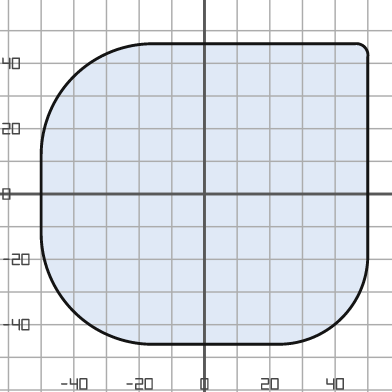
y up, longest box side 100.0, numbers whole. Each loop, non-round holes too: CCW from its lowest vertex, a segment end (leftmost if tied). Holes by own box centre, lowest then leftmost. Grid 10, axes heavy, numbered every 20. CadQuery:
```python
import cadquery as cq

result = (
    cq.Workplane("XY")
    .moveTo(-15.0, -46.0)
    .lineTo(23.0, -46.0)
    .threePointArc((42.0, -38.0), (50.0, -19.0))
    .lineTo(50.0, 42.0)
    .threePointArc((49.0, 45.0), (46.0, 46.0))
    .lineTo(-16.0, 46.0)
    .threePointArc((-40.0, 36.0), (-50.0, 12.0))
    .lineTo(-50.0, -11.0)
    .threePointArc((-40.0, -36.0), (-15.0, -46.0))
    .close()
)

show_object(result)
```